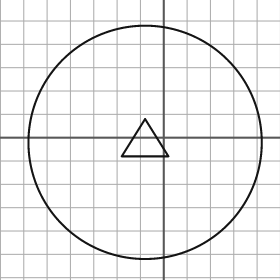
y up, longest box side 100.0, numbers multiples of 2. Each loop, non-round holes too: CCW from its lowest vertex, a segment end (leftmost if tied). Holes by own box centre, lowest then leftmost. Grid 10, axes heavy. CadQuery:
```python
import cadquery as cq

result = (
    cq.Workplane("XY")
    .moveTo(-8.0, -2.0)
    .circle(50.0)
    .moveTo(-18.0, -8.0)
    .lineTo(2.0, -8.0)
    .lineTo(-8.0, 8.0)
    .close()
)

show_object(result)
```